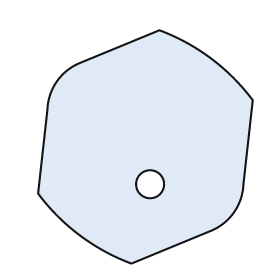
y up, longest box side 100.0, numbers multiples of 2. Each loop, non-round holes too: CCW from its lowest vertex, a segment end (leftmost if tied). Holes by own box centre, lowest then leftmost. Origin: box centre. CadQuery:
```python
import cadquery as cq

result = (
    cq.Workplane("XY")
    .moveTo(-6.0, -50.0)
    .lineTo(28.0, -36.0)
    .threePointArc((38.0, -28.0), (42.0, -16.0))
    .lineTo(46.0, 20.0)
    .threePointArc((28.0, 38.0), (6.0, 50.0))
    .lineTo(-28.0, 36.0)
    .threePointArc((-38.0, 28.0), (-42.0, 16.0))
    .lineTo(-46.0, -20.0)
    .threePointArc((-28.0, -38.0), (-6.0, -50.0))
    .close()
    .moveTo(2.0, -16.0)
    .circle(6.0)
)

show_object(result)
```